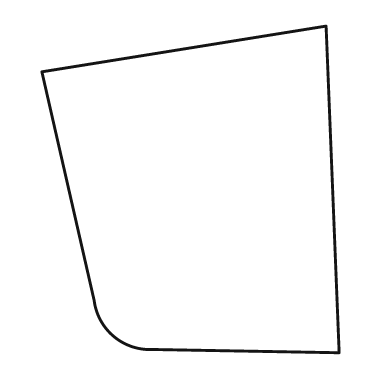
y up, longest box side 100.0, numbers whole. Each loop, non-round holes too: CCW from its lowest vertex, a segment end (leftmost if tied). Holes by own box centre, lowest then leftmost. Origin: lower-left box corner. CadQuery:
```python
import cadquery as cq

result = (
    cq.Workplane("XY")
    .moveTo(91.0, 0.0)
    .lineTo(87.0, 100.0)
    .lineTo(0.0, 86.0)
    .lineTo(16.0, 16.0)
    .threePointArc((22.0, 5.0), (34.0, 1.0))
    .close()
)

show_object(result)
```